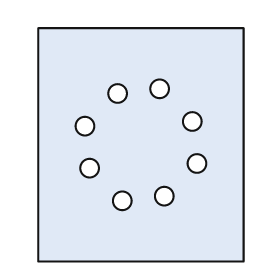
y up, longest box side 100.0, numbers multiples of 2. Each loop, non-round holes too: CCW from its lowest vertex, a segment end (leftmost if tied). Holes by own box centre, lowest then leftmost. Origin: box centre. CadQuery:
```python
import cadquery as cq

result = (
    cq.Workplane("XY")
    .moveTo(-44.0, -50.0)
    .lineTo(44.0, -50.0)
    .lineTo(44.0, 50.0)
    .lineTo(-44.0, 50.0)
    .close()
    .moveTo(-8.0, -24.0)
    .circle(4.0)
    .moveTo(10.0, -22.0)
    .circle(4.0)
    .moveTo(-22.0, -10.0)
    .circle(4.0)
    .moveTo(24.0, -8.0)
    .circle(4.0)
    .moveTo(-24.0, 8.0)
    .circle(4.0)
    .moveTo(22.0, 10.0)
    .circle(4.0)
    .moveTo(-10.0, 22.0)
    .circle(4.0)
    .moveTo(8.0, 24.0)
    .circle(4.0)
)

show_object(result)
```